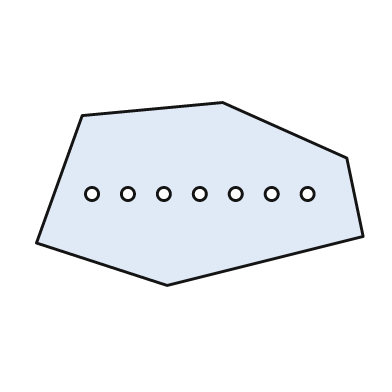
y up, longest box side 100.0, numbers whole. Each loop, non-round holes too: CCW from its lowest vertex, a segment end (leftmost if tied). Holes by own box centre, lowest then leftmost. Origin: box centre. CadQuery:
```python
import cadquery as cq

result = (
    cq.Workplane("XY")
    .moveTo(-10.0, -28.0)
    .lineTo(50.0, -13.0)
    .lineTo(45.0, 11.0)
    .lineTo(7.0, 28.0)
    .lineTo(-36.0, 24.0)
    .lineTo(-50.0, -15.0)
    .close()
    .moveTo(-33.0, 0.0)
    .circle(2.0)
    .moveTo(-22.0, 0.0)
    .circle(2.0)
    .moveTo(-11.0, 0.0)
    .circle(2.0)
    .moveTo(0.0, 0.0)
    .circle(2.0)
    .moveTo(11.0, 0.0)
    .circle(2.0)
    .moveTo(22.0, 0.0)
    .circle(2.0)
    .moveTo(33.0, 0.0)
    .circle(2.0)
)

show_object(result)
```